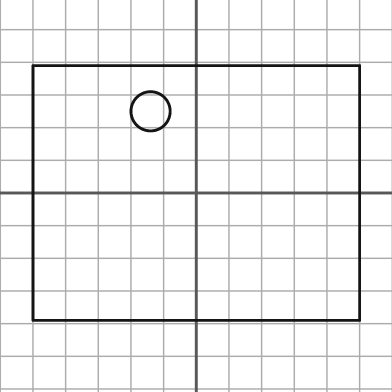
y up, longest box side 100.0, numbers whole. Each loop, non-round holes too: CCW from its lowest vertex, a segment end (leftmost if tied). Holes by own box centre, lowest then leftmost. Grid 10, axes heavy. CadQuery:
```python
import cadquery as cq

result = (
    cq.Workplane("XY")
    .moveTo(-50.0, -39.0)
    .lineTo(50.0, -39.0)
    .lineTo(50.0, 39.0)
    .lineTo(-50.0, 39.0)
    .close()
    .moveTo(-14.0, 25.0)
    .circle(6.0)
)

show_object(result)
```